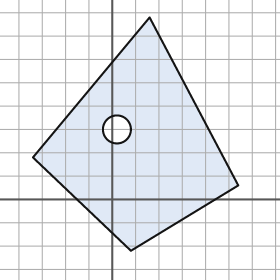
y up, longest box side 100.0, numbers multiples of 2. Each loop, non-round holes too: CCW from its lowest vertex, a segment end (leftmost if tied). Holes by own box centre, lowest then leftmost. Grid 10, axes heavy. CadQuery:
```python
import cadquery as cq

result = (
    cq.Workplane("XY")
    .moveTo(8.0, -22.0)
    .lineTo(54.0, 6.0)
    .lineTo(16.0, 78.0)
    .lineTo(-34.0, 18.0)
    .close()
    .moveTo(2.0, 30.0)
    .circle(6.0)
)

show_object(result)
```